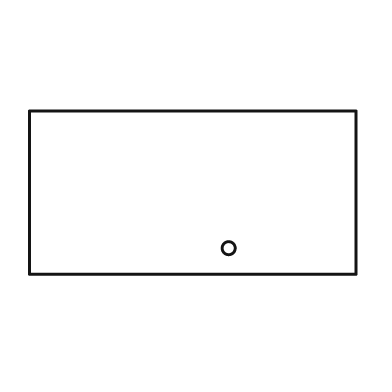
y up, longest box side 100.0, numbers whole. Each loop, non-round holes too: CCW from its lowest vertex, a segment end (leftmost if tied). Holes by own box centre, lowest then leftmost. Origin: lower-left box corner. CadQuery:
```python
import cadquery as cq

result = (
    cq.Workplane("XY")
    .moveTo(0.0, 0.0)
    .lineTo(100.0, 0.0)
    .lineTo(100.0, 50.0)
    .lineTo(0.0, 50.0)
    .close()
    .moveTo(61.0, 8.0)
    .circle(2.0)
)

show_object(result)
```